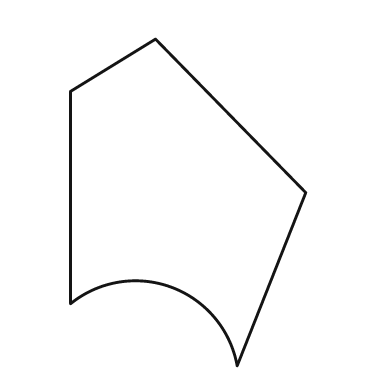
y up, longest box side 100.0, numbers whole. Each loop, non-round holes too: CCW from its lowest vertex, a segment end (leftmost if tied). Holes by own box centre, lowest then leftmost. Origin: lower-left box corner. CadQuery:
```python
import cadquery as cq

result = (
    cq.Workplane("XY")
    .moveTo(51.0, 0.0)
    .lineTo(72.0, 53.0)
    .lineTo(26.0, 100.0)
    .lineTo(0.0, 84.0)
    .lineTo(0.0, 19.0)
    .threePointArc((31.0, 24.0), (51.0, 0.0))
    .close()
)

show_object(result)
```